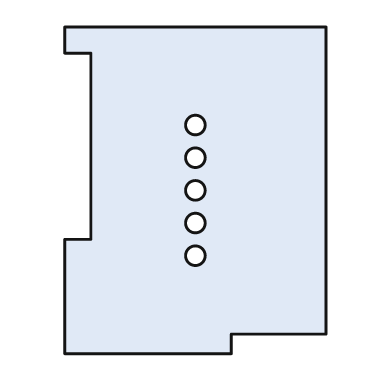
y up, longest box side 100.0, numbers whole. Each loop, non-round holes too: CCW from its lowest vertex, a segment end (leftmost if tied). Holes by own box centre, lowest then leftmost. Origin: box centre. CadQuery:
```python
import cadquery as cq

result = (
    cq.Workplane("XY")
    .moveTo(-40.0, -50.0)
    .lineTo(11.0, -50.0)
    .lineTo(11.0, -44.0)
    .lineTo(40.0, -44.0)
    .lineTo(40.0, 50.0)
    .lineTo(-40.0, 50.0)
    .lineTo(-40.0, 42.0)
    .lineTo(-32.0, 42.0)
    .lineTo(-32.0, -15.0)
    .lineTo(-40.0, -15.0)
    .close()
    .moveTo(0.0, -20.0)
    .circle(3.0)
    .moveTo(0.0, -10.0)
    .circle(3.0)
    .moveTo(0.0, 0.0)
    .circle(3.0)
    .moveTo(0.0, 10.0)
    .circle(3.0)
    .moveTo(0.0, 20.0)
    .circle(3.0)
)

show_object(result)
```